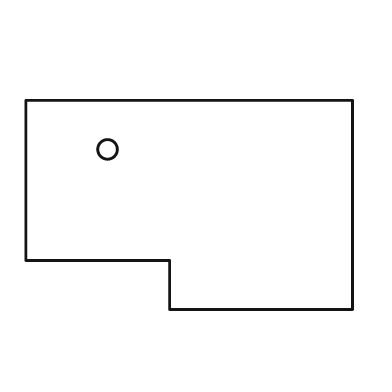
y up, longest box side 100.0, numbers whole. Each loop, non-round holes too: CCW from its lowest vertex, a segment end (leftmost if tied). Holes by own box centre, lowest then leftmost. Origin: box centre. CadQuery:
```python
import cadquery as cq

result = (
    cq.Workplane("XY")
    .moveTo(-6.0, -32.0)
    .lineTo(50.0, -32.0)
    .lineTo(50.0, 32.0)
    .lineTo(-50.0, 32.0)
    .lineTo(-50.0, -17.0)
    .lineTo(-6.0, -17.0)
    .close()
    .moveTo(-25.0, 17.0)
    .circle(3.0)
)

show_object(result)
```